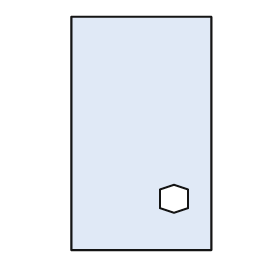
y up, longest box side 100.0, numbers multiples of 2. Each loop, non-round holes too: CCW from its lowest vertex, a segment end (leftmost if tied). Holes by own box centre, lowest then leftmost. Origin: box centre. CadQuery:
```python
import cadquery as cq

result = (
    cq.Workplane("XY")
    .moveTo(-30.0, -50.0)
    .lineTo(30.0, -50.0)
    .lineTo(30.0, 50.0)
    .lineTo(-30.0, 50.0)
    .close()
    .moveTo(14.0, -34.0)
    .lineTo(20.0, -32.0)
    .lineTo(20.0, -24.0)
    .lineTo(14.0, -22.0)
    .lineTo(8.0, -24.0)
    .lineTo(8.0, -32.0)
    .close()
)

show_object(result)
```